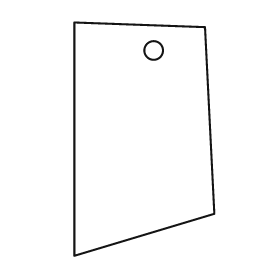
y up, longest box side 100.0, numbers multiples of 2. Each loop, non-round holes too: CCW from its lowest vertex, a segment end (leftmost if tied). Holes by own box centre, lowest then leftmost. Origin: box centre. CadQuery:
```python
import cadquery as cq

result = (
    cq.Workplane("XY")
    .moveTo(-30.0, -50.0)
    .lineTo(30.0, -32.0)
    .lineTo(26.0, 48.0)
    .lineTo(-30.0, 50.0)
    .close()
    .moveTo(4.0, 38.0)
    .circle(4.0)
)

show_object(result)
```